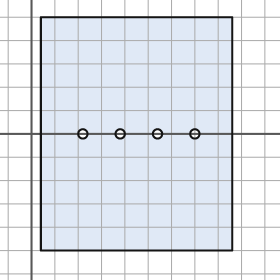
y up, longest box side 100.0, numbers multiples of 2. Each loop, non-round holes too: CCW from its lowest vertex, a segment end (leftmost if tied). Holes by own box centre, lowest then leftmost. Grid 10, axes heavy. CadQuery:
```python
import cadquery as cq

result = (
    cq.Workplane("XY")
    .moveTo(4.0, -50.0)
    .lineTo(86.0, -50.0)
    .lineTo(86.0, 50.0)
    .lineTo(4.0, 50.0)
    .close()
    .moveTo(22.0, 0.0)
    .circle(2.0)
    .moveTo(38.0, 0.0)
    .circle(2.0)
    .moveTo(54.0, 0.0)
    .circle(2.0)
    .moveTo(70.0, 0.0)
    .circle(2.0)
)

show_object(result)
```